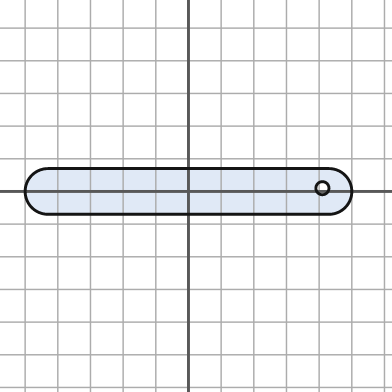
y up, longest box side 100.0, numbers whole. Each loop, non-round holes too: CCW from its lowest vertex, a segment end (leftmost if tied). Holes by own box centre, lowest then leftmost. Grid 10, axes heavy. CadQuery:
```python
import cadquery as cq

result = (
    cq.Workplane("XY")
    .moveTo(-43.0, -7.0)
    .lineTo(43.0, -7.0)
    .threePointArc((50.0, 0.0), (43.0, 7.0))
    .lineTo(-43.0, 7.0)
    .threePointArc((-50.0, 0.0), (-43.0, -7.0))
    .close()
    .moveTo(41.0, 1.0)
    .circle(2.0)
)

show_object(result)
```